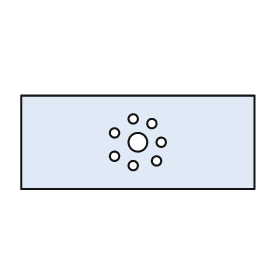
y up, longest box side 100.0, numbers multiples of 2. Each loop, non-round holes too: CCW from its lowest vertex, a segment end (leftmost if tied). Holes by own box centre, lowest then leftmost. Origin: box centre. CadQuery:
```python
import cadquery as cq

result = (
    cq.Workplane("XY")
    .moveTo(-50.0, -20.0)
    .lineTo(50.0, -20.0)
    .lineTo(50.0, 20.0)
    .lineTo(-50.0, 20.0)
    .close()
    .moveTo(-2.0, -10.0)
    .circle(2.0)
    .moveTo(8.0, -8.0)
    .circle(2.0)
    .moveTo(-10.0, -6.0)
    .circle(2.0)
    .moveTo(0.0, 0.0)
    .circle(4.0)
    .moveTo(10.0, 0.0)
    .circle(2.0)
    .moveTo(-10.0, 4.0)
    .circle(2.0)
    .moveTo(6.0, 8.0)
    .circle(2.0)
    .moveTo(-2.0, 10.0)
    .circle(2.0)
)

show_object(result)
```